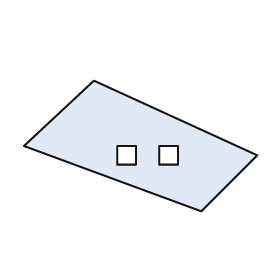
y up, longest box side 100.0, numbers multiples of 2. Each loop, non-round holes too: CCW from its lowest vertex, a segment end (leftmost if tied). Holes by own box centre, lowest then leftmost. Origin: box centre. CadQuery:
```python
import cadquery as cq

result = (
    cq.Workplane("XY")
    .moveTo(26.0, -28.0)
    .lineTo(50.0, -4.0)
    .lineTo(-20.0, 28.0)
    .lineTo(-50.0, 0.0)
    .close()
    .moveTo(-10.0, -8.0)
    .lineTo(-2.0, -8.0)
    .lineTo(-2.0, 0.0)
    .lineTo(-10.0, 0.0)
    .close()
    .moveTo(8.0, -8.0)
    .lineTo(16.0, -8.0)
    .lineTo(16.0, 0.0)
    .lineTo(8.0, 0.0)
    .close()
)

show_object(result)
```